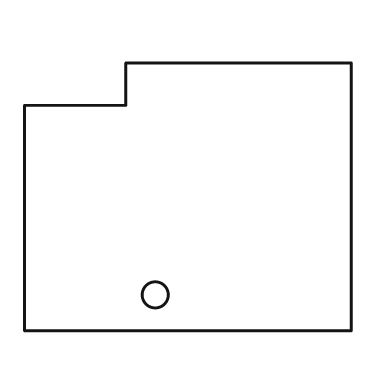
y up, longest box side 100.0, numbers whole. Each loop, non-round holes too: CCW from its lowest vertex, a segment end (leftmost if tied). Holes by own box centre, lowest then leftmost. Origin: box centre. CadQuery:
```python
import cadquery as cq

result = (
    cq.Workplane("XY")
    .moveTo(-50.0, -41.0)
    .lineTo(50.0, -41.0)
    .lineTo(50.0, 41.0)
    .lineTo(-19.0, 41.0)
    .lineTo(-19.0, 28.0)
    .lineTo(-50.0, 28.0)
    .close()
    .moveTo(-10.0, -30.0)
    .circle(4.0)
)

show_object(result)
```